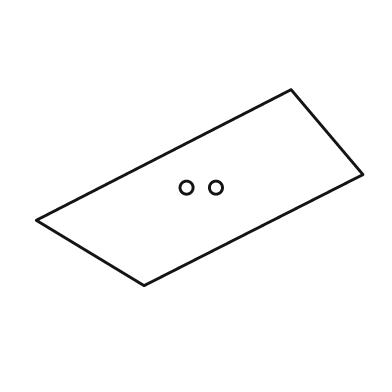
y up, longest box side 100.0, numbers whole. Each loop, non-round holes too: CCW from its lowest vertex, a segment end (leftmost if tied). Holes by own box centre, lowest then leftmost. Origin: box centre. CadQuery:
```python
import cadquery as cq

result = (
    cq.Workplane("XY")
    .moveTo(-17.0, -30.0)
    .lineTo(50.0, 4.0)
    .lineTo(28.0, 30.0)
    .lineTo(-50.0, -10.0)
    .close()
    .moveTo(-4.0, 0.0)
    .circle(2.0)
    .moveTo(5.0, 0.0)
    .circle(2.0)
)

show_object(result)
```